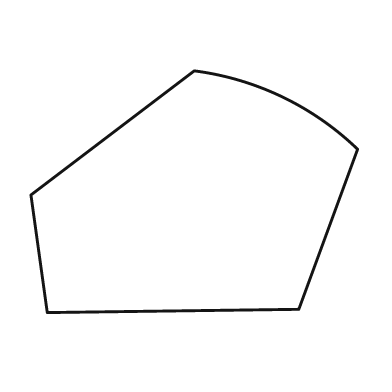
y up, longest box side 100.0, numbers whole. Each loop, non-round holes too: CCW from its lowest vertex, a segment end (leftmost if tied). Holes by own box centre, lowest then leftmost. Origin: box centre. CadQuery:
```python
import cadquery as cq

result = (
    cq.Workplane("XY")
    .moveTo(-45.0, -37.0)
    .lineTo(32.0, -36.0)
    .lineTo(50.0, 13.0)
    .threePointArc((27.0, 29.0), (0.0, 37.0))
    .lineTo(-50.0, -1.0)
    .close()
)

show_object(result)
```